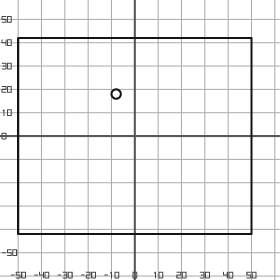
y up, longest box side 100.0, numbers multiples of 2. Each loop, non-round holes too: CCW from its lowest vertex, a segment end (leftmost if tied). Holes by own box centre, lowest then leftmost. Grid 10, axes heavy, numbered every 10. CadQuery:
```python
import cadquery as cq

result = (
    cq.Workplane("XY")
    .moveTo(-50.0, -42.0)
    .lineTo(50.0, -42.0)
    .lineTo(50.0, 42.0)
    .lineTo(-50.0, 42.0)
    .close()
    .moveTo(-8.0, 18.0)
    .circle(2.0)
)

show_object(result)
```